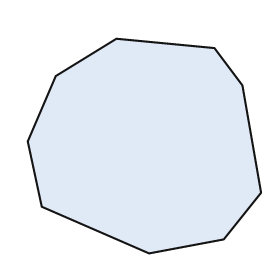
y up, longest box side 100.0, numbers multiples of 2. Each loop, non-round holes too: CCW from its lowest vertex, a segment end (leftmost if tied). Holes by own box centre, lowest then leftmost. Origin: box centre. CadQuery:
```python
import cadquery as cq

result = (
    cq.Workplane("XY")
    .moveTo(2.0, -46.0)
    .lineTo(34.0, -40.0)
    .lineTo(50.0, -20.0)
    .lineTo(42.0, 26.0)
    .lineTo(30.0, 42.0)
    .lineTo(-12.0, 46.0)
    .lineTo(-38.0, 30.0)
    .lineTo(-50.0, 2.0)
    .lineTo(-44.0, -26.0)
    .close()
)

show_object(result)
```